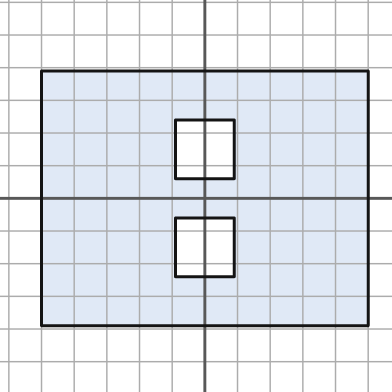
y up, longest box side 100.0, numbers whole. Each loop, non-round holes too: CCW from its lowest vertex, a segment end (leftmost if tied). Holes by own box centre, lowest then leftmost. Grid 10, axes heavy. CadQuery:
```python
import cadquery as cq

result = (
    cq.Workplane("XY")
    .moveTo(-50.0, -39.0)
    .lineTo(50.0, -39.0)
    .lineTo(50.0, 39.0)
    .lineTo(-50.0, 39.0)
    .close()
    .moveTo(-9.0, -24.0)
    .lineTo(9.0, -24.0)
    .lineTo(9.0, -6.0)
    .lineTo(-9.0, -6.0)
    .close()
    .moveTo(-9.0, 6.0)
    .lineTo(9.0, 6.0)
    .lineTo(9.0, 24.0)
    .lineTo(-9.0, 24.0)
    .close()
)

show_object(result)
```